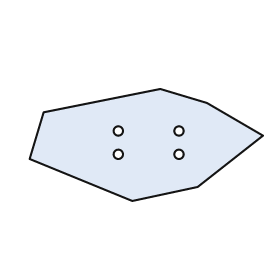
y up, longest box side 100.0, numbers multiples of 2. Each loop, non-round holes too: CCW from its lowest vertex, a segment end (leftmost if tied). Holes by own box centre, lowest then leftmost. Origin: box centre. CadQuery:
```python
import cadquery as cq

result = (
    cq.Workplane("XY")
    .moveTo(-6.0, -24.0)
    .lineTo(22.0, -18.0)
    .lineTo(50.0, 4.0)
    .lineTo(26.0, 18.0)
    .lineTo(6.0, 24.0)
    .lineTo(-44.0, 14.0)
    .lineTo(-50.0, -6.0)
    .close()
    .moveTo(-12.0, -4.0)
    .circle(2.0)
    .moveTo(14.0, -4.0)
    .circle(2.0)
    .moveTo(-12.0, 6.0)
    .circle(2.0)
    .moveTo(14.0, 6.0)
    .circle(2.0)
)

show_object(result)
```